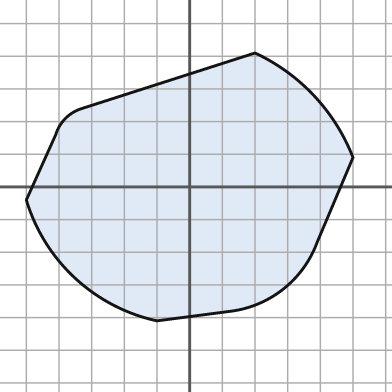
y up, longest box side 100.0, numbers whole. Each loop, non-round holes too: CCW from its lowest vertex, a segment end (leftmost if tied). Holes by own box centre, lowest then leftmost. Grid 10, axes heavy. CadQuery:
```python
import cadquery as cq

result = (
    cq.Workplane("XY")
    .moveTo(-10.0, -41.0)
    .lineTo(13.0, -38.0)
    .threePointArc((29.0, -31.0), (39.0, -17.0))
    .lineTo(50.0, 9.0)
    .threePointArc((38.0, 28.0), (20.0, 41.0))
    .lineTo(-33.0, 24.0)
    .threePointArc((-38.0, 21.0), (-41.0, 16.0))
    .lineTo(-50.0, -4.0)
    .threePointArc((-35.0, -28.0), (-10.0, -41.0))
    .close()
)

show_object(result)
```